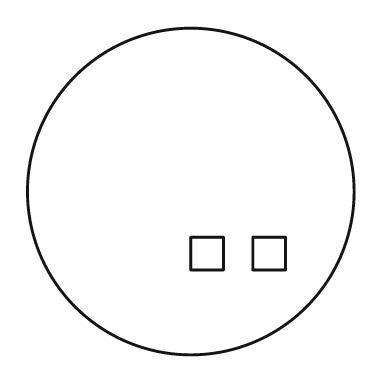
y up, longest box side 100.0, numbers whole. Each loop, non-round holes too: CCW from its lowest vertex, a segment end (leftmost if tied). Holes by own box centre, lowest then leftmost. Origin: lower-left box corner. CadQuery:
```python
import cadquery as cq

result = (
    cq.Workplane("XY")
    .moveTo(50.0, 50.0)
    .circle(50.0)
    .moveTo(50.0, 26.0)
    .lineTo(60.0, 26.0)
    .lineTo(60.0, 36.0)
    .lineTo(50.0, 36.0)
    .close()
    .moveTo(69.0, 26.0)
    .lineTo(79.0, 26.0)
    .lineTo(79.0, 36.0)
    .lineTo(69.0, 36.0)
    .close()
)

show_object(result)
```